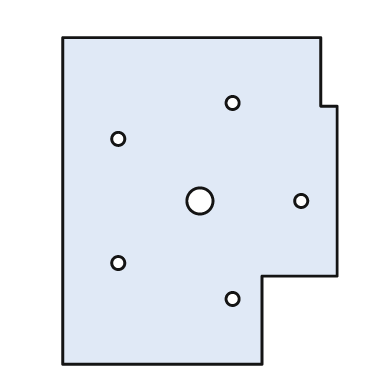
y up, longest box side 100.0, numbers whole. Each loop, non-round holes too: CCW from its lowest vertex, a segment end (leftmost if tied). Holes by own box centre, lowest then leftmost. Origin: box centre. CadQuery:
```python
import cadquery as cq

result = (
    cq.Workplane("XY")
    .moveTo(-42.0, -50.0)
    .lineTo(19.0, -50.0)
    .lineTo(19.0, -23.0)
    .lineTo(42.0, -23.0)
    .lineTo(42.0, 29.0)
    .lineTo(37.0, 29.0)
    .lineTo(37.0, 50.0)
    .lineTo(-42.0, 50.0)
    .close()
    .moveTo(10.0, -30.0)
    .circle(2.0)
    .moveTo(-25.0, -19.0)
    .circle(2.0)
    .moveTo(0.0, 0.0)
    .circle(4.0)
    .moveTo(31.0, 0.0)
    .circle(2.0)
    .moveTo(-25.0, 19.0)
    .circle(2.0)
    .moveTo(10.0, 30.0)
    .circle(2.0)
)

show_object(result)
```